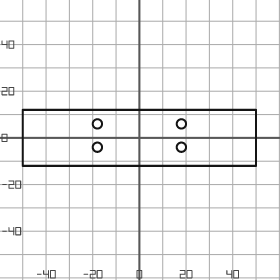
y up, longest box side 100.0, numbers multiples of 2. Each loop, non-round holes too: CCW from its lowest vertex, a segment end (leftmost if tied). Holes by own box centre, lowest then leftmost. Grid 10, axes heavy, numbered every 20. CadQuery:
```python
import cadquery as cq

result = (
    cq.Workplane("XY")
    .moveTo(-50.0, -12.0)
    .lineTo(50.0, -12.0)
    .lineTo(50.0, 12.0)
    .lineTo(-50.0, 12.0)
    .close()
    .moveTo(-18.0, -4.0)
    .circle(2.0)
    .moveTo(18.0, -4.0)
    .circle(2.0)
    .moveTo(-18.0, 6.0)
    .circle(2.0)
    .moveTo(18.0, 6.0)
    .circle(2.0)
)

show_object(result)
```